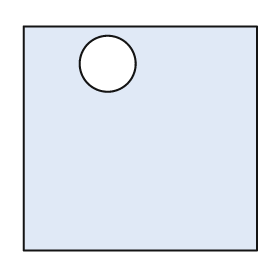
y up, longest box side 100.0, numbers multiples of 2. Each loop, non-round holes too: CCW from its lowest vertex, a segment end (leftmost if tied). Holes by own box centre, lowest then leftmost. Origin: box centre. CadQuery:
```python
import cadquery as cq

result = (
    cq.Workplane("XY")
    .moveTo(-50.0, -48.0)
    .lineTo(50.0, -48.0)
    .lineTo(50.0, 48.0)
    .lineTo(-50.0, 48.0)
    .close()
    .moveTo(-14.0, 32.0)
    .circle(12.0)
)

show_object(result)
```